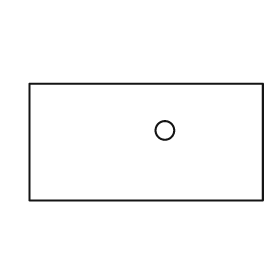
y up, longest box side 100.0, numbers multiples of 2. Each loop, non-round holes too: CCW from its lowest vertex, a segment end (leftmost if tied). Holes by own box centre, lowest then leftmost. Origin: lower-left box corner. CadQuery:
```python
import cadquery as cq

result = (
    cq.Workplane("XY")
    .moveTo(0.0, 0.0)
    .lineTo(100.0, 0.0)
    .lineTo(100.0, 50.0)
    .lineTo(0.0, 50.0)
    .close()
    .moveTo(58.0, 30.0)
    .circle(4.0)
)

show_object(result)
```